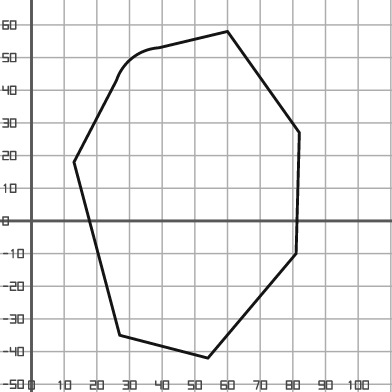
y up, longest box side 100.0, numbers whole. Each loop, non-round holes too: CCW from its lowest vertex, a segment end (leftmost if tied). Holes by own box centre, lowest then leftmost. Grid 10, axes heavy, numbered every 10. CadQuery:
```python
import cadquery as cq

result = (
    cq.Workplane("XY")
    .moveTo(54.0, -42.0)
    .lineTo(81.0, -10.0)
    .lineTo(82.0, 27.0)
    .lineTo(60.0, 58.0)
    .lineTo(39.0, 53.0)
    .threePointArc((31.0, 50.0), (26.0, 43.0))
    .lineTo(13.0, 18.0)
    .lineTo(27.0, -35.0)
    .close()
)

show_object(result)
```